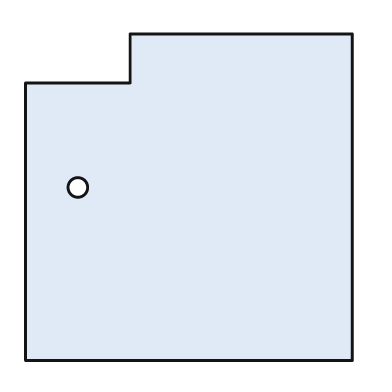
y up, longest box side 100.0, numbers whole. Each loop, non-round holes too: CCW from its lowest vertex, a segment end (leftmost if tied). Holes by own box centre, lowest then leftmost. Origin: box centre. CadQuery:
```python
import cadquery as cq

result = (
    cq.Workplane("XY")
    .moveTo(-50.0, -50.0)
    .lineTo(50.0, -50.0)
    .lineTo(50.0, 50.0)
    .lineTo(-18.0, 50.0)
    .lineTo(-18.0, 35.0)
    .lineTo(-50.0, 35.0)
    .close()
    .moveTo(-34.0, 3.0)
    .circle(3.0)
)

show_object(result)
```